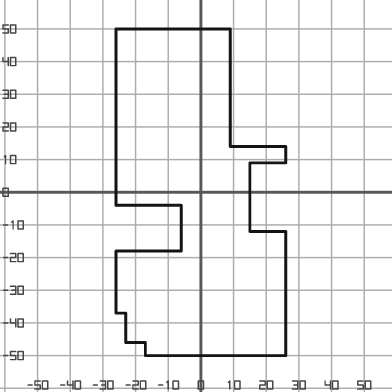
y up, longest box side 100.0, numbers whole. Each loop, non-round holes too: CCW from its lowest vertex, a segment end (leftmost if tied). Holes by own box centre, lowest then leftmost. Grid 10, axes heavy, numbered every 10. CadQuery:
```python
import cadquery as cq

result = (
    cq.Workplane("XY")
    .moveTo(-17.0, -50.0)
    .lineTo(26.0, -50.0)
    .lineTo(26.0, -12.0)
    .lineTo(15.0, -12.0)
    .lineTo(15.0, 9.0)
    .lineTo(26.0, 9.0)
    .lineTo(26.0, 14.0)
    .lineTo(9.0, 14.0)
    .lineTo(9.0, 50.0)
    .lineTo(-26.0, 50.0)
    .lineTo(-26.0, -4.0)
    .lineTo(-6.0, -4.0)
    .lineTo(-6.0, -18.0)
    .lineTo(-26.0, -18.0)
    .lineTo(-26.0, -37.0)
    .lineTo(-23.0, -37.0)
    .lineTo(-23.0, -46.0)
    .lineTo(-17.0, -46.0)
    .close()
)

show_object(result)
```